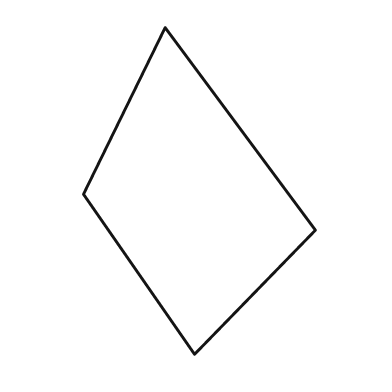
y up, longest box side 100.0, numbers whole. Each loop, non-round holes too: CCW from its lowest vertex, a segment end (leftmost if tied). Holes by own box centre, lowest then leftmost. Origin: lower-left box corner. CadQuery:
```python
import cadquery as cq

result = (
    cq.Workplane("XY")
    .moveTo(34.0, 0.0)
    .lineTo(71.0, 38.0)
    .lineTo(25.0, 100.0)
    .lineTo(0.0, 49.0)
    .close()
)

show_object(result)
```